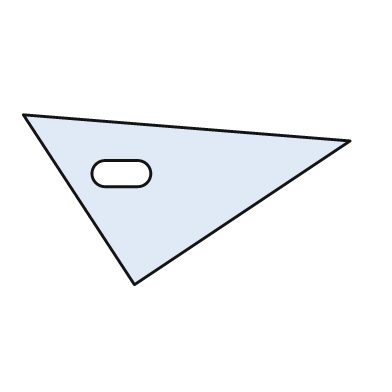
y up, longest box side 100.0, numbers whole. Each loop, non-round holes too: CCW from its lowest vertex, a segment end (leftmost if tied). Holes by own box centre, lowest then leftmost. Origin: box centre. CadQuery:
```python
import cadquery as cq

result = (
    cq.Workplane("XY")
    .moveTo(-16.0, -26.0)
    .lineTo(50.0, 18.0)
    .lineTo(-50.0, 26.0)
    .close()
    .moveTo(-25.0, 4.0)
    .lineTo(-15.0, 4.0)
    .threePointArc((-11.0, 8.0), (-15.0, 12.0))
    .lineTo(-25.0, 12.0)
    .threePointArc((-29.0, 8.0), (-25.0, 4.0))
    .close()
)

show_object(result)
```